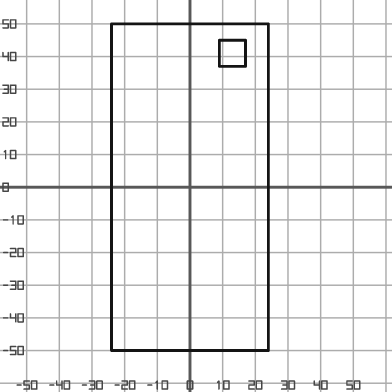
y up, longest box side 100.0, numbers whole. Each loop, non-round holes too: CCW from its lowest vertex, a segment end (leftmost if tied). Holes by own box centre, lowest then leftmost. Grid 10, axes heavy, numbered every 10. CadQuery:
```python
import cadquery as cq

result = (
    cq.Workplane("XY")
    .moveTo(-24.0, -50.0)
    .lineTo(24.0, -50.0)
    .lineTo(24.0, 50.0)
    .lineTo(-24.0, 50.0)
    .close()
    .moveTo(9.0, 37.0)
    .lineTo(17.0, 37.0)
    .lineTo(17.0, 45.0)
    .lineTo(9.0, 45.0)
    .close()
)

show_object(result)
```